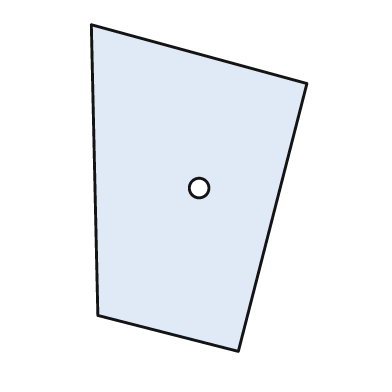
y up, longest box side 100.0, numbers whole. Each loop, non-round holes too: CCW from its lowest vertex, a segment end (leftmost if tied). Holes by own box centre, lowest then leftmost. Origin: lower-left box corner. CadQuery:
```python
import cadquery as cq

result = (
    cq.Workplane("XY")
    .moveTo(45.0, 0.0)
    .lineTo(66.0, 82.0)
    .lineTo(0.0, 100.0)
    .lineTo(2.0, 11.0)
    .close()
    .moveTo(33.0, 50.0)
    .circle(3.0)
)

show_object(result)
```